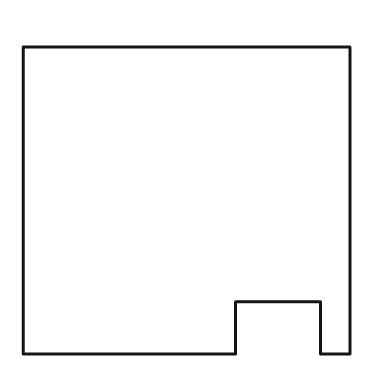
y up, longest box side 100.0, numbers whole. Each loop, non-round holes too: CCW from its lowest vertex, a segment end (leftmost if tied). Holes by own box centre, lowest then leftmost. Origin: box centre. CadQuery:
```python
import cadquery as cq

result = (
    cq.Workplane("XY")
    .moveTo(-50.0, -47.0)
    .lineTo(15.0, -47.0)
    .lineTo(15.0, -31.0)
    .lineTo(41.0, -31.0)
    .lineTo(41.0, -47.0)
    .lineTo(50.0, -47.0)
    .lineTo(50.0, 47.0)
    .lineTo(-50.0, 47.0)
    .close()
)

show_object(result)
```